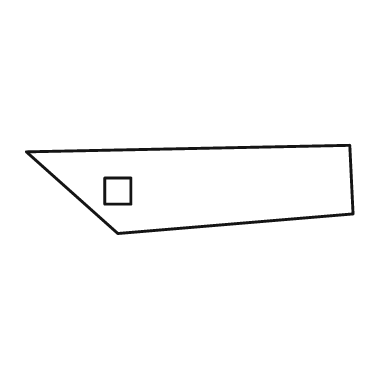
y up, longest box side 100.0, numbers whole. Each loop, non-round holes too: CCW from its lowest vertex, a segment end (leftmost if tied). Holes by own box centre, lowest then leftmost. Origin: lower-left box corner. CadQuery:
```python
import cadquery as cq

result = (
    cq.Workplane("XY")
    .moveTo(28.0, 0.0)
    .lineTo(100.0, 6.0)
    .lineTo(99.0, 27.0)
    .lineTo(0.0, 25.0)
    .close()
    .moveTo(24.0, 9.0)
    .lineTo(32.0, 9.0)
    .lineTo(32.0, 17.0)
    .lineTo(24.0, 17.0)
    .close()
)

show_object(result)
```